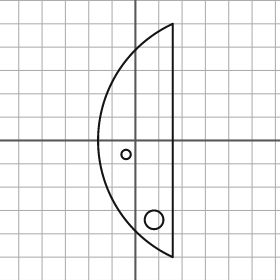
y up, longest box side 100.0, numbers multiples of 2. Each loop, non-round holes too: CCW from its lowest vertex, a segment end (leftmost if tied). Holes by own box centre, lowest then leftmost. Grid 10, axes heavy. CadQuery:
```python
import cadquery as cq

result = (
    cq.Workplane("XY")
    .moveTo(16.0, -50.0)
    .lineTo(16.0, 50.0)
    .threePointArc((-16.0, 0.0), (16.0, -50.0))
    .close()
    .moveTo(8.0, -34.0)
    .circle(4.0)
    .moveTo(-4.0, -6.0)
    .circle(2.0)
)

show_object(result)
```